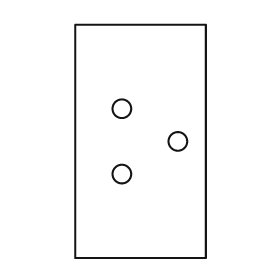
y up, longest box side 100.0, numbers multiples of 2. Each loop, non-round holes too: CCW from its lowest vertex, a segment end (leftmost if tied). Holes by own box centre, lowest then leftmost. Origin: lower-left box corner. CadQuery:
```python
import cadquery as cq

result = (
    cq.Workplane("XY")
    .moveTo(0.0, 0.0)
    .lineTo(56.0, 0.0)
    .lineTo(56.0, 100.0)
    .lineTo(0.0, 100.0)
    .close()
    .moveTo(20.0, 36.0)
    .circle(4.0)
    .moveTo(44.0, 50.0)
    .circle(4.0)
    .moveTo(20.0, 64.0)
    .circle(4.0)
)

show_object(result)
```